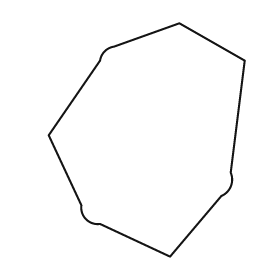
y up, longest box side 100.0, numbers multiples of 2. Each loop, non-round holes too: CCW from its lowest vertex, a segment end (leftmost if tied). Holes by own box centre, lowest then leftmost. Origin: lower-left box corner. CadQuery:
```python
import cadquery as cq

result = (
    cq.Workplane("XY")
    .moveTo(52.0, 0.0)
    .lineTo(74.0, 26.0)
    .threePointArc((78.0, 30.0), (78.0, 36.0))
    .lineTo(84.0, 84.0)
    .lineTo(56.0, 100.0)
    .lineTo(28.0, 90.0)
    .threePointArc((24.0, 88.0), (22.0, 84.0))
    .lineTo(0.0, 52.0)
    .lineTo(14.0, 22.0)
    .threePointArc((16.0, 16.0), (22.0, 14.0))
    .close()
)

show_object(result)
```